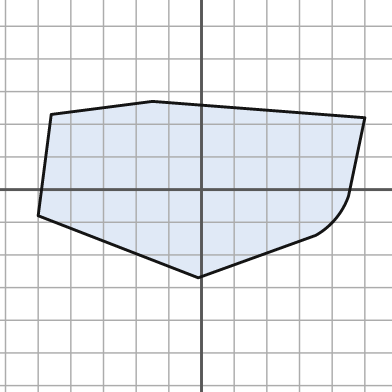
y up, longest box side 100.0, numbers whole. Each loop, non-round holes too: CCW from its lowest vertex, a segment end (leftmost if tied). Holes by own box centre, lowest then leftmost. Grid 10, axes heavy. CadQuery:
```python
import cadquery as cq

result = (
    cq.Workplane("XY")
    .moveTo(-1.0, -27.0)
    .lineTo(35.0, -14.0)
    .threePointArc((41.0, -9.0), (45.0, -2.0))
    .lineTo(50.0, 22.0)
    .lineTo(-15.0, 27.0)
    .lineTo(-46.0, 23.0)
    .lineTo(-50.0, -8.0)
    .close()
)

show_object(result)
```